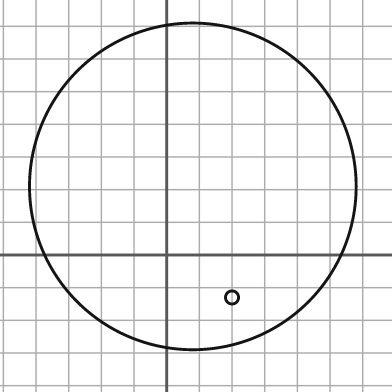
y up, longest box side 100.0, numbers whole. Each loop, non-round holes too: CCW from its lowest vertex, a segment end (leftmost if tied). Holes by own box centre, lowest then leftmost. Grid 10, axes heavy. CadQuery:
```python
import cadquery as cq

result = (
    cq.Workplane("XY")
    .moveTo(8.0, 21.0)
    .circle(50.0)
    .moveTo(20.0, -13.0)
    .circle(2.0)
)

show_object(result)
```